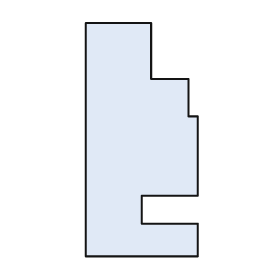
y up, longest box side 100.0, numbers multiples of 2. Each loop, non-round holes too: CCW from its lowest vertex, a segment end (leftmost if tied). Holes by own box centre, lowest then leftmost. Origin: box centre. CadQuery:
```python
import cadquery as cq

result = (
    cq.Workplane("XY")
    .moveTo(-24.0, -50.0)
    .lineTo(24.0, -50.0)
    .lineTo(24.0, -36.0)
    .lineTo(0.0, -36.0)
    .lineTo(0.0, -24.0)
    .lineTo(24.0, -24.0)
    .lineTo(24.0, 10.0)
    .lineTo(20.0, 10.0)
    .lineTo(20.0, 26.0)
    .lineTo(4.0, 26.0)
    .lineTo(4.0, 50.0)
    .lineTo(-24.0, 50.0)
    .close()
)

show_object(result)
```